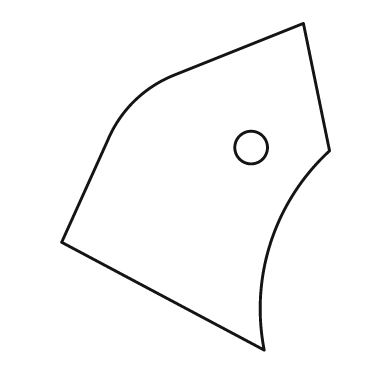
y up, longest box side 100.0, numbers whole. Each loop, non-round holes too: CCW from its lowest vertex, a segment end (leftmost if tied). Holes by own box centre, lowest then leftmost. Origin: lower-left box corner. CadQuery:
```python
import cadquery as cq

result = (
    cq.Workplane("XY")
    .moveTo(62.0, 0.0)
    .threePointArc((64.0, 33.0), (82.0, 61.0))
    .lineTo(74.0, 100.0)
    .lineTo(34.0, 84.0)
    .threePointArc((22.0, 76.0), (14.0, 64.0))
    .lineTo(0.0, 33.0)
    .close()
    .moveTo(58.0, 62.0)
    .circle(5.0)
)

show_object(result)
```